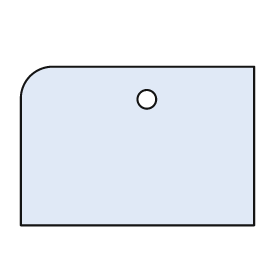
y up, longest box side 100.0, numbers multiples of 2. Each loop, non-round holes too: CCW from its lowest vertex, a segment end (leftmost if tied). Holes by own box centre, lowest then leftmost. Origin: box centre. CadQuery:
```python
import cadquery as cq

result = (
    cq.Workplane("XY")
    .moveTo(-50.0, -34.0)
    .lineTo(50.0, -34.0)
    .lineTo(50.0, 34.0)
    .lineTo(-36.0, 34.0)
    .threePointArc((-46.0, 30.0), (-50.0, 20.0))
    .close()
    .moveTo(4.0, 20.0)
    .circle(4.0)
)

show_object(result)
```